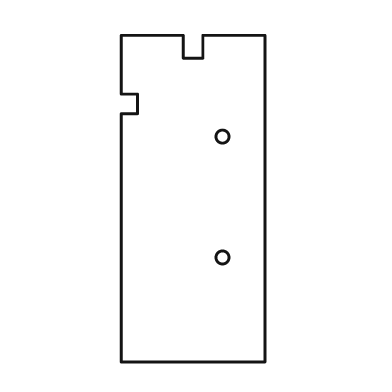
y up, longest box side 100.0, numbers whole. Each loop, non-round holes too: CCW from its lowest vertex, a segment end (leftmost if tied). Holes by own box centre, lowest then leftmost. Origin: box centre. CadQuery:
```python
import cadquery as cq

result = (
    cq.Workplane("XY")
    .moveTo(-22.0, -50.0)
    .lineTo(22.0, -50.0)
    .lineTo(22.0, 50.0)
    .lineTo(3.0, 50.0)
    .lineTo(3.0, 43.0)
    .lineTo(-3.0, 43.0)
    .lineTo(-3.0, 50.0)
    .lineTo(-22.0, 50.0)
    .lineTo(-22.0, 32.0)
    .lineTo(-17.0, 32.0)
    .lineTo(-17.0, 26.0)
    .lineTo(-22.0, 26.0)
    .close()
    .moveTo(9.0, -18.0)
    .circle(2.0)
    .moveTo(9.0, 19.0)
    .circle(2.0)
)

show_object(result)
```